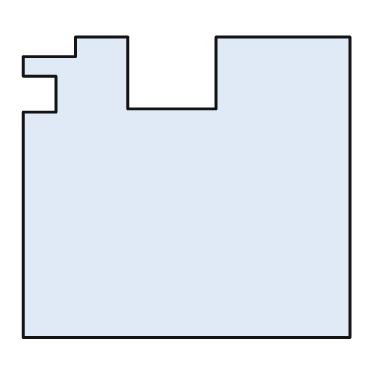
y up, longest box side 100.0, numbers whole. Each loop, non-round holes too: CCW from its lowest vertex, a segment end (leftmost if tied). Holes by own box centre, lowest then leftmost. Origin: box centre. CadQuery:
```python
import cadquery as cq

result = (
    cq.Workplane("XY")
    .moveTo(-50.0, -46.0)
    .lineTo(50.0, -46.0)
    .lineTo(50.0, 46.0)
    .lineTo(9.0, 46.0)
    .lineTo(9.0, 24.0)
    .lineTo(-18.0, 24.0)
    .lineTo(-18.0, 46.0)
    .lineTo(-34.0, 46.0)
    .lineTo(-34.0, 40.0)
    .lineTo(-50.0, 40.0)
    .lineTo(-50.0, 34.0)
    .lineTo(-40.0, 34.0)
    .lineTo(-40.0, 23.0)
    .lineTo(-50.0, 23.0)
    .close()
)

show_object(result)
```